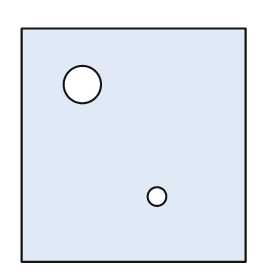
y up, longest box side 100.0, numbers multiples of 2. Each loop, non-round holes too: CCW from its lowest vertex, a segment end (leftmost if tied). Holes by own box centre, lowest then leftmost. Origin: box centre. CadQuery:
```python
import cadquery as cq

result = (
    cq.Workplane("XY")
    .moveTo(-48.0, -50.0)
    .lineTo(48.0, -50.0)
    .lineTo(48.0, 50.0)
    .lineTo(-48.0, 50.0)
    .close()
    .moveTo(10.0, -22.0)
    .circle(4.0)
    .moveTo(-22.0, 26.0)
    .circle(8.0)
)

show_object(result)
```